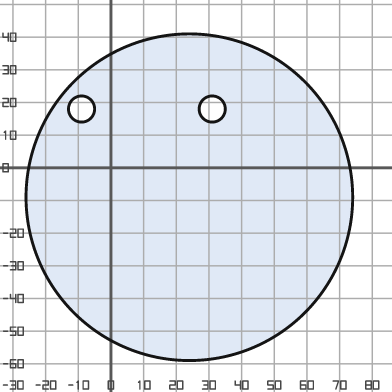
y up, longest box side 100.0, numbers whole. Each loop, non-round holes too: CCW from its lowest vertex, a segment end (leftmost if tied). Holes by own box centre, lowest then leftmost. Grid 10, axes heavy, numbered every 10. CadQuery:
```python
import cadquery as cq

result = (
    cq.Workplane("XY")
    .moveTo(24.0, -9.0)
    .circle(50.0)
    .moveTo(-9.0, 18.0)
    .circle(4.0)
    .moveTo(31.0, 18.0)
    .circle(4.0)
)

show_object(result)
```